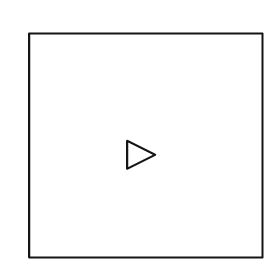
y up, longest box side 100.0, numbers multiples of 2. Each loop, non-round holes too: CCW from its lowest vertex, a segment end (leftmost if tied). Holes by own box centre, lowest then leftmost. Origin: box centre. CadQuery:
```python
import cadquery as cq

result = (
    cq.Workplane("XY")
    .moveTo(-50.0, -48.0)
    .lineTo(50.0, -48.0)
    .lineTo(50.0, 48.0)
    .lineTo(-50.0, 48.0)
    .close()
    .moveTo(-8.0, -10.0)
    .lineTo(4.0, -4.0)
    .lineTo(-8.0, 2.0)
    .close()
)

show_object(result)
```